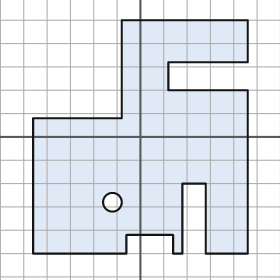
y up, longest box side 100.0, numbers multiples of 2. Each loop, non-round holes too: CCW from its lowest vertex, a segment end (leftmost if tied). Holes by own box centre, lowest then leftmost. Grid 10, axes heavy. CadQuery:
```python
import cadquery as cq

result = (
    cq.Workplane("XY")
    .moveTo(-46.0, -50.0)
    .lineTo(-6.0, -50.0)
    .lineTo(-6.0, -42.0)
    .lineTo(14.0, -42.0)
    .lineTo(14.0, -50.0)
    .lineTo(18.0, -50.0)
    .lineTo(18.0, -20.0)
    .lineTo(28.0, -20.0)
    .lineTo(28.0, -50.0)
    .lineTo(46.0, -50.0)
    .lineTo(46.0, 20.0)
    .lineTo(12.0, 20.0)
    .lineTo(12.0, 32.0)
    .lineTo(46.0, 32.0)
    .lineTo(46.0, 50.0)
    .lineTo(-8.0, 50.0)
    .lineTo(-8.0, 8.0)
    .lineTo(-46.0, 8.0)
    .close()
    .moveTo(-12.0, -28.0)
    .circle(4.0)
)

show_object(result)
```